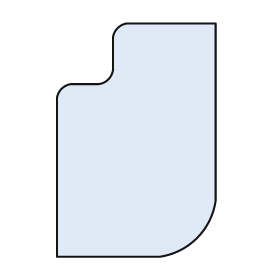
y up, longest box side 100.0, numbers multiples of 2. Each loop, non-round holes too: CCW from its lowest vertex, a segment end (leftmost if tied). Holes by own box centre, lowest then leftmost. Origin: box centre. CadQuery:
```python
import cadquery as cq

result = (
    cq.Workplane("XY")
    .moveTo(-34.0, -50.0)
    .lineTo(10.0, -50.0)
    .threePointArc((26.0, -42.0), (34.0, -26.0))
    .lineTo(34.0, 50.0)
    .lineTo(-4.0, 50.0)
    .threePointArc((-8.0, 48.0), (-10.0, 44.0))
    .lineTo(-10.0, 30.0)
    .threePointArc((-12.0, 26.0), (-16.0, 24.0))
    .lineTo(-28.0, 24.0)
    .threePointArc((-32.0, 22.0), (-34.0, 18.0))
    .close()
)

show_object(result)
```